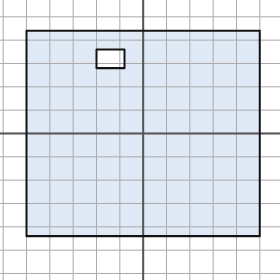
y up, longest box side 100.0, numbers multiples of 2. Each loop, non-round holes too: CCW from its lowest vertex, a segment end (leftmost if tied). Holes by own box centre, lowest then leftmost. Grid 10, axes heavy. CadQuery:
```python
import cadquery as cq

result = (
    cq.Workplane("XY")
    .moveTo(-50.0, -44.0)
    .lineTo(50.0, -44.0)
    .lineTo(50.0, 44.0)
    .lineTo(-50.0, 44.0)
    .close()
    .moveTo(-20.0, 28.0)
    .lineTo(-8.0, 28.0)
    .lineTo(-8.0, 36.0)
    .lineTo(-20.0, 36.0)
    .close()
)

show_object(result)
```